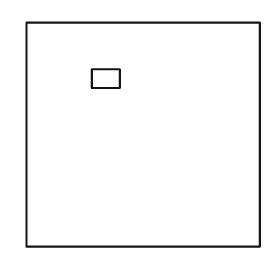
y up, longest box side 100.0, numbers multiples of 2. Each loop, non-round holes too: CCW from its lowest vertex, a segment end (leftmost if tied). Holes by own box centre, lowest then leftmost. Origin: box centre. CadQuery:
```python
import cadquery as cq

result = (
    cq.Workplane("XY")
    .moveTo(-50.0, -48.0)
    .lineTo(50.0, -48.0)
    .lineTo(50.0, 48.0)
    .lineTo(-50.0, 48.0)
    .close()
    .moveTo(-22.0, 20.0)
    .lineTo(-10.0, 20.0)
    .lineTo(-10.0, 28.0)
    .lineTo(-22.0, 28.0)
    .close()
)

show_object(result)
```